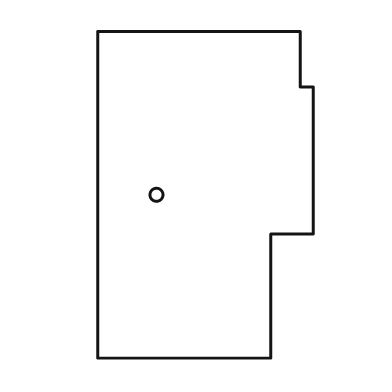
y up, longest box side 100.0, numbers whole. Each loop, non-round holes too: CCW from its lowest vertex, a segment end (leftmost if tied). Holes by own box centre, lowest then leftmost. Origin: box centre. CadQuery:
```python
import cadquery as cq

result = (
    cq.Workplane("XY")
    .moveTo(-33.0, -50.0)
    .lineTo(20.0, -50.0)
    .lineTo(20.0, -12.0)
    .lineTo(33.0, -12.0)
    .lineTo(33.0, 33.0)
    .lineTo(29.0, 33.0)
    .lineTo(29.0, 50.0)
    .lineTo(-33.0, 50.0)
    .close()
    .moveTo(-15.0, 0.0)
    .circle(2.0)
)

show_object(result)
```